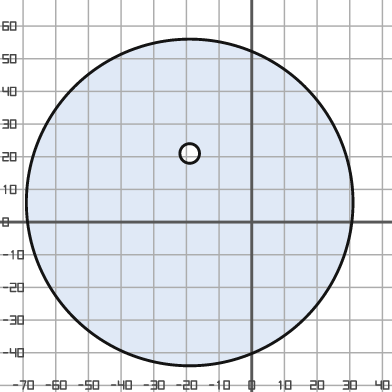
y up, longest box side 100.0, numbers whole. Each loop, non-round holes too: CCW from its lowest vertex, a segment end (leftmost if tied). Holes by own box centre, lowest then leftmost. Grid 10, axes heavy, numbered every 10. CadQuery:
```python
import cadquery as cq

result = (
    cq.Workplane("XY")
    .moveTo(-19.0, 6.0)
    .circle(50.0)
    .moveTo(-19.0, 21.0)
    .circle(3.0)
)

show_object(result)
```